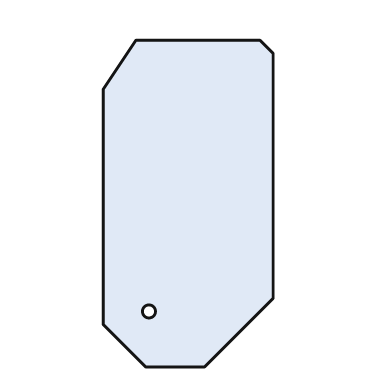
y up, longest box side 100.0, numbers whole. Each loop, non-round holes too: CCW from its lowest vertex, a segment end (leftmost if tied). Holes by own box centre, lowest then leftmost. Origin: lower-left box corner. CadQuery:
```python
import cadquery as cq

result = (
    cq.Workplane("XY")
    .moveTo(13.0, 0.0)
    .lineTo(31.0, 0.0)
    .lineTo(52.0, 21.0)
    .lineTo(52.0, 96.0)
    .lineTo(48.0, 100.0)
    .lineTo(10.0, 100.0)
    .lineTo(0.0, 85.0)
    .lineTo(0.0, 13.0)
    .close()
    .moveTo(14.0, 17.0)
    .circle(2.0)
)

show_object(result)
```